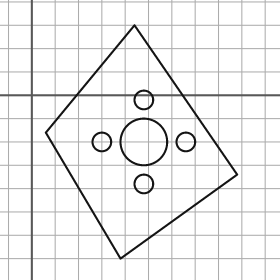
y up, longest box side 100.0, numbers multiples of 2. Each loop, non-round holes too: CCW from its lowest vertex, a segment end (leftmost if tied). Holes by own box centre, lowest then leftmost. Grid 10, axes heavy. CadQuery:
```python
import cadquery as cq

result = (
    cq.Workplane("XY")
    .moveTo(38.0, -70.0)
    .lineTo(88.0, -34.0)
    .lineTo(44.0, 30.0)
    .lineTo(6.0, -16.0)
    .close()
    .moveTo(48.0, -38.0)
    .circle(4.0)
    .moveTo(30.0, -20.0)
    .circle(4.0)
    .moveTo(48.0, -20.0)
    .circle(10.0)
    .moveTo(66.0, -20.0)
    .circle(4.0)
    .moveTo(48.0, -2.0)
    .circle(4.0)
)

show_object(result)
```